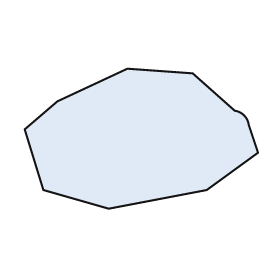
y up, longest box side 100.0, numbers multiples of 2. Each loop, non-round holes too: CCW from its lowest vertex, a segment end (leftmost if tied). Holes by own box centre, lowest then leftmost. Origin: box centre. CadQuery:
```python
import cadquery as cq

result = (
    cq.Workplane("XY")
    .moveTo(-14.0, -30.0)
    .lineTo(28.0, -22.0)
    .lineTo(50.0, -6.0)
    .lineTo(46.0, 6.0)
    .threePointArc((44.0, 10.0), (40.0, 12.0))
    .lineTo(22.0, 28.0)
    .lineTo(-6.0, 30.0)
    .lineTo(-36.0, 16.0)
    .lineTo(-50.0, 4.0)
    .lineTo(-42.0, -22.0)
    .close()
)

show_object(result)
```